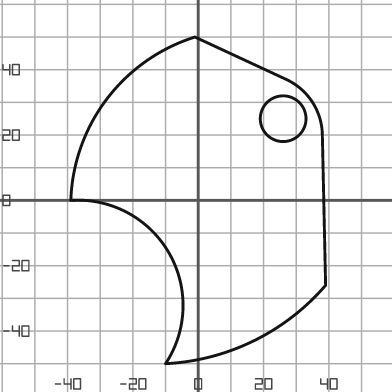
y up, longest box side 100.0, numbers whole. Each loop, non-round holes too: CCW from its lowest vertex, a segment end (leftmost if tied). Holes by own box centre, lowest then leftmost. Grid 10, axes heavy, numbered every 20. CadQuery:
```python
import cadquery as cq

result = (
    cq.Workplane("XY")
    .moveTo(-10.0, -50.0)
    .threePointArc((17.0, -43.0), (39.0, -26.0))
    .lineTo(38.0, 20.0)
    .threePointArc((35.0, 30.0), (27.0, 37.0))
    .lineTo(-1.0, 50.0)
    .threePointArc((-28.0, 31.0), (-39.0, 0.0))
    .threePointArc((-9.0, -16.0), (-10.0, -50.0))
    .close()
    .moveTo(26.0, 25.0)
    .circle(7.0)
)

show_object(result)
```